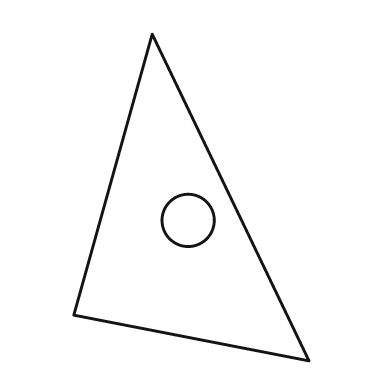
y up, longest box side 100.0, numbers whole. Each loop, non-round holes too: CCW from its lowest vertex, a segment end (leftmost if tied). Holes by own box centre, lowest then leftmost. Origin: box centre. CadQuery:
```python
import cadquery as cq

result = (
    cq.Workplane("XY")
    .moveTo(36.0, -50.0)
    .lineTo(-12.0, 50.0)
    .lineTo(-36.0, -36.0)
    .close()
    .moveTo(-1.0, -7.0)
    .circle(8.0)
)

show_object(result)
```